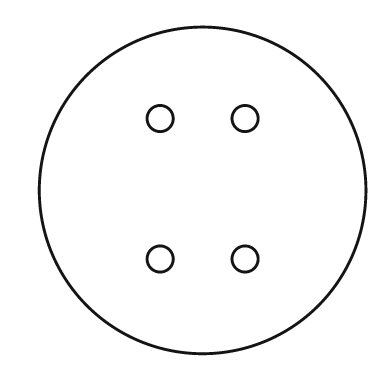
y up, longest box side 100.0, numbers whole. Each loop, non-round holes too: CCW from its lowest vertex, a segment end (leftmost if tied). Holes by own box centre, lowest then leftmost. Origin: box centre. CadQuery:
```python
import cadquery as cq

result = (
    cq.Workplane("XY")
    .moveTo(0.0, 0.0)
    .circle(50.0)
    .moveTo(-13.0, -21.0)
    .circle(4.0)
    .moveTo(13.0, -21.0)
    .circle(4.0)
    .moveTo(-13.0, 22.0)
    .circle(4.0)
    .moveTo(13.0, 22.0)
    .circle(4.0)
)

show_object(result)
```